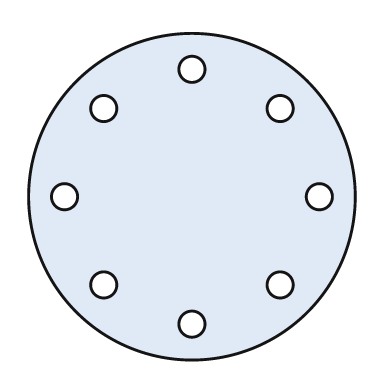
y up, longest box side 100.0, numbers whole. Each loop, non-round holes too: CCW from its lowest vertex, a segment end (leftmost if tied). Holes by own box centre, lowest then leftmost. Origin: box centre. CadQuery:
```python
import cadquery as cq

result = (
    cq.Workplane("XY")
    .moveTo(0.0, 0.0)
    .circle(50.0)
    .moveTo(0.0, -39.0)
    .circle(4.0)
    .moveTo(-27.0, -27.0)
    .circle(4.0)
    .moveTo(27.0, -27.0)
    .circle(4.0)
    .moveTo(-39.0, 0.0)
    .circle(4.0)
    .moveTo(39.0, 0.0)
    .circle(4.0)
    .moveTo(-27.0, 27.0)
    .circle(4.0)
    .moveTo(27.0, 27.0)
    .circle(4.0)
    .moveTo(0.0, 39.0)
    .circle(4.0)
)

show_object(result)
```